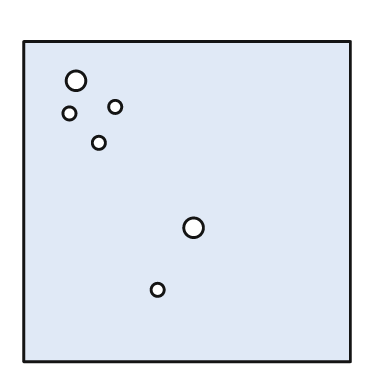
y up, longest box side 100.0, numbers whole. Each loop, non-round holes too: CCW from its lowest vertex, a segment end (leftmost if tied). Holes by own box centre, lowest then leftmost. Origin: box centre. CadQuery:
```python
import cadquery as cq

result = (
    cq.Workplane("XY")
    .moveTo(-50.0, -49.0)
    .lineTo(50.0, -49.0)
    .lineTo(50.0, 49.0)
    .lineTo(-50.0, 49.0)
    .close()
    .moveTo(-9.0, -27.0)
    .circle(2.0)
    .moveTo(2.0, -8.0)
    .circle(3.0)
    .moveTo(-27.0, 18.0)
    .circle(2.0)
    .moveTo(-36.0, 27.0)
    .circle(2.0)
    .moveTo(-22.0, 29.0)
    .circle(2.0)
    .moveTo(-34.0, 37.0)
    .circle(3.0)
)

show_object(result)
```